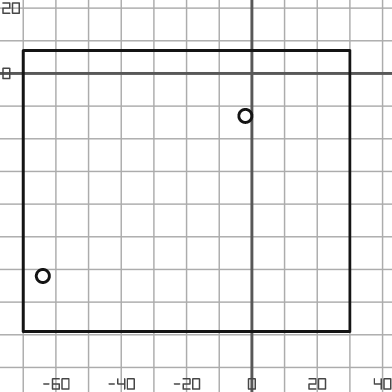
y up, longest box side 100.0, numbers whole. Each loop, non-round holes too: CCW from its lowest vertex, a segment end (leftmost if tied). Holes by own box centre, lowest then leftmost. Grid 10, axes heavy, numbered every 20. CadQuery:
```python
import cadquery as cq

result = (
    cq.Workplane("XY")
    .moveTo(-70.0, -79.0)
    .lineTo(30.0, -79.0)
    .lineTo(30.0, 7.0)
    .lineTo(-70.0, 7.0)
    .close()
    .moveTo(-64.0, -62.0)
    .circle(2.0)
    .moveTo(-2.0, -13.0)
    .circle(2.0)
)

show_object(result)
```